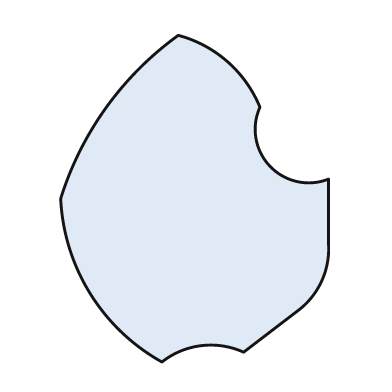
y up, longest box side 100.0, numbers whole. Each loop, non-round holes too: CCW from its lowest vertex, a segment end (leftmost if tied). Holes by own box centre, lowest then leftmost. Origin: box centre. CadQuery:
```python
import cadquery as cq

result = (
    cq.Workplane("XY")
    .moveTo(-10.0, -50.0)
    .threePointArc((2.0, -45.0), (15.0, -47.0))
    .lineTo(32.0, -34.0)
    .threePointArc((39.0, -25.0), (41.0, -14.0))
    .lineTo(41.0, 6.0)
    .threePointArc((23.0, 10.0), (20.0, 28.0))
    .threePointArc((10.0, 42.0), (-5.0, 50.0))
    .threePointArc((-27.0, 28.0), (-41.0, 0.0))
    .threePointArc((-32.0, -29.0), (-10.0, -50.0))
    .close()
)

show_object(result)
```